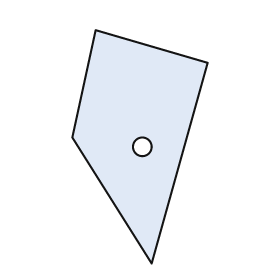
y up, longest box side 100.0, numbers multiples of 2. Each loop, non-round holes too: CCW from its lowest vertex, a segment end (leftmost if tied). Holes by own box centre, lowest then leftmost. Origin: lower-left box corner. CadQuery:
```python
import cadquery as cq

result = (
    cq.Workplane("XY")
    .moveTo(34.0, 0.0)
    .lineTo(58.0, 86.0)
    .lineTo(10.0, 100.0)
    .lineTo(0.0, 54.0)
    .close()
    .moveTo(30.0, 50.0)
    .circle(4.0)
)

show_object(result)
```